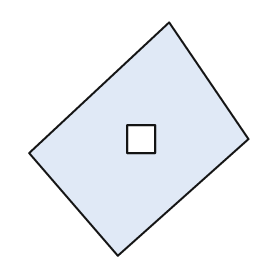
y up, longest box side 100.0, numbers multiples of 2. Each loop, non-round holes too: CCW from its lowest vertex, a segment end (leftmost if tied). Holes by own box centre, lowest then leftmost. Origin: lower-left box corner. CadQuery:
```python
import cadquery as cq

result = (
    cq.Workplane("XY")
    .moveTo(38.0, 0.0)
    .lineTo(94.0, 50.0)
    .lineTo(60.0, 100.0)
    .lineTo(0.0, 44.0)
    .close()
    .moveTo(42.0, 44.0)
    .lineTo(54.0, 44.0)
    .lineTo(54.0, 56.0)
    .lineTo(42.0, 56.0)
    .close()
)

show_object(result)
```